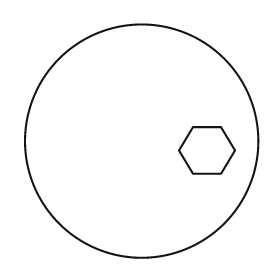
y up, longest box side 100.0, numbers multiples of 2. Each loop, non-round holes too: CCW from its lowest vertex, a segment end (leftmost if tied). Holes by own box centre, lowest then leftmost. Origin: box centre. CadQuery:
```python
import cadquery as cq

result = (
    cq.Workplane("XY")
    .moveTo(0.0, 0.0)
    .circle(50.0)
    .moveTo(22.0, -14.0)
    .lineTo(34.0, -14.0)
    .lineTo(40.0, -4.0)
    .lineTo(34.0, 6.0)
    .lineTo(22.0, 6.0)
    .lineTo(16.0, -4.0)
    .close()
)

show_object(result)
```